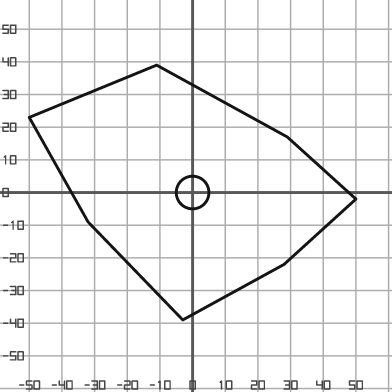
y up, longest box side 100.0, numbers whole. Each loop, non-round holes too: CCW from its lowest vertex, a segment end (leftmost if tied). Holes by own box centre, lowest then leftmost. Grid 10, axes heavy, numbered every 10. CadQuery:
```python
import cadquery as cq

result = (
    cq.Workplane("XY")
    .moveTo(-3.0, -39.0)
    .lineTo(28.0, -22.0)
    .lineTo(50.0, -2.0)
    .lineTo(29.0, 17.0)
    .lineTo(-11.0, 39.0)
    .lineTo(-50.0, 23.0)
    .lineTo(-32.0, -9.0)
    .close()
    .moveTo(0.0, 0.0)
    .circle(5.0)
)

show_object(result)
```